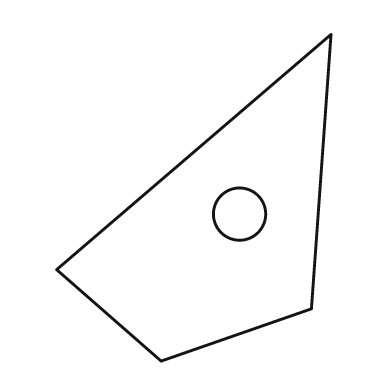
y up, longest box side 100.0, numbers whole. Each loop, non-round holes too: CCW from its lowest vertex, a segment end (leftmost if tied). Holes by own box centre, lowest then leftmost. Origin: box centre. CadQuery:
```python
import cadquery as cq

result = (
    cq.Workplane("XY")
    .moveTo(-10.0, -50.0)
    .lineTo(36.0, -34.0)
    .lineTo(42.0, 50.0)
    .lineTo(-42.0, -22.0)
    .close()
    .moveTo(14.0, -5.0)
    .circle(8.0)
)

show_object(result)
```